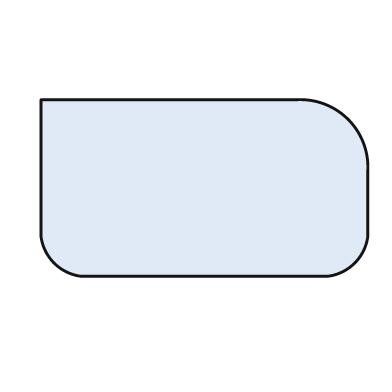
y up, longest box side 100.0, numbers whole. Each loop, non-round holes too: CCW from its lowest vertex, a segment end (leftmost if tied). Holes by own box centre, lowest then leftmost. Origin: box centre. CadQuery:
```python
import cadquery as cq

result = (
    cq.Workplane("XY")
    .moveTo(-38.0, -27.0)
    .lineTo(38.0, -27.0)
    .threePointArc((46.0, -23.0), (50.0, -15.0))
    .lineTo(50.0, 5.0)
    .threePointArc((44.0, 21.0), (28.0, 27.0))
    .lineTo(-50.0, 27.0)
    .lineTo(-50.0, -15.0)
    .threePointArc((-46.0, -23.0), (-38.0, -27.0))
    .close()
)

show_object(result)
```